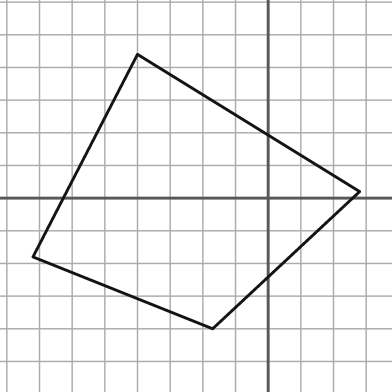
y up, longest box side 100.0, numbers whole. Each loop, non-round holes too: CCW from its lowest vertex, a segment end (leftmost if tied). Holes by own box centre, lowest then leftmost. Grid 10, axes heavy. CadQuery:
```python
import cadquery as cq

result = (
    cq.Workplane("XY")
    .moveTo(-17.0, -40.0)
    .lineTo(28.0, 2.0)
    .lineTo(-40.0, 44.0)
    .lineTo(-72.0, -18.0)
    .close()
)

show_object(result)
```